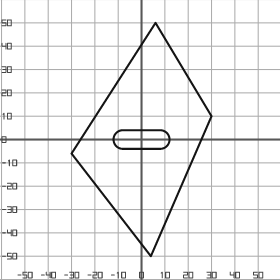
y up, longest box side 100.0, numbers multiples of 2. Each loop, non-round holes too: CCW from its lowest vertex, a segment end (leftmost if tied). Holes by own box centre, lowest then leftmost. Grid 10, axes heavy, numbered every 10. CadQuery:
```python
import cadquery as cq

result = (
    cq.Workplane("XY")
    .moveTo(4.0, -50.0)
    .lineTo(30.0, 10.0)
    .lineTo(6.0, 50.0)
    .lineTo(-30.0, -6.0)
    .close()
    .moveTo(-8.0, -4.0)
    .lineTo(8.0, -4.0)
    .threePointArc((12.0, 0.0), (8.0, 4.0))
    .lineTo(-8.0, 4.0)
    .threePointArc((-12.0, 0.0), (-8.0, -4.0))
    .close()
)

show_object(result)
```